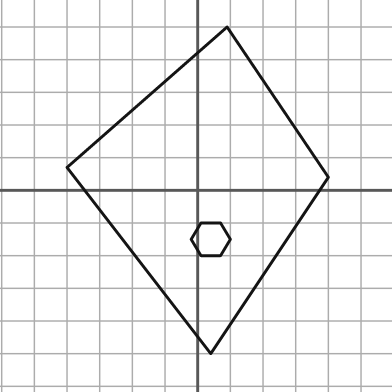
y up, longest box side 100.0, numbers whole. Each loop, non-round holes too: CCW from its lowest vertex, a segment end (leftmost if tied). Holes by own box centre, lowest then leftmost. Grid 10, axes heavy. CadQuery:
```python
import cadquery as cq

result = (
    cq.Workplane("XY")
    .moveTo(4.0, -50.0)
    .lineTo(40.0, 4.0)
    .lineTo(9.0, 50.0)
    .lineTo(-40.0, 7.0)
    .close()
    .moveTo(1.0, -20.0)
    .lineTo(7.0, -20.0)
    .lineTo(10.0, -15.0)
    .lineTo(7.0, -10.0)
    .lineTo(1.0, -10.0)
    .lineTo(-2.0, -15.0)
    .close()
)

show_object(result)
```